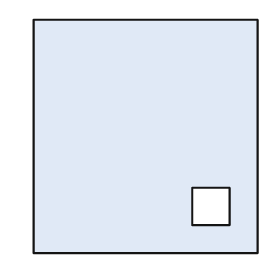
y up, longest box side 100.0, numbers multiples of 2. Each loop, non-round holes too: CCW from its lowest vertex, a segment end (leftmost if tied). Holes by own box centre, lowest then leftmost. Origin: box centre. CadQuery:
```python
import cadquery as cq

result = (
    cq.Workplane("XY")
    .moveTo(-48.0, -50.0)
    .lineTo(48.0, -50.0)
    .lineTo(48.0, 50.0)
    .lineTo(-48.0, 50.0)
    .close()
    .moveTo(20.0, -38.0)
    .lineTo(36.0, -38.0)
    .lineTo(36.0, -22.0)
    .lineTo(20.0, -22.0)
    .close()
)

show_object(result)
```